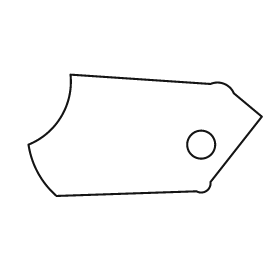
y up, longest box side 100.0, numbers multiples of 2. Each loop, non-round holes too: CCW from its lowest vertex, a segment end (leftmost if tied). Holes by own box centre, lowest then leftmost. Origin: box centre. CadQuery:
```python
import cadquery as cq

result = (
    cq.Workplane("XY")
    .moveTo(-38.0, -26.0)
    .lineTo(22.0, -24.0)
    .threePointArc((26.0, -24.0), (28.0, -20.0))
    .lineTo(50.0, 8.0)
    .lineTo(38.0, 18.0)
    .threePointArc((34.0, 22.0), (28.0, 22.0))
    .lineTo(-32.0, 26.0)
    .threePointArc((-36.0, 8.0), (-50.0, -4.0))
    .threePointArc((-46.0, -16.0), (-38.0, -26.0))
    .close()
    .moveTo(24.0, -4.0)
    .circle(6.0)
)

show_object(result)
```